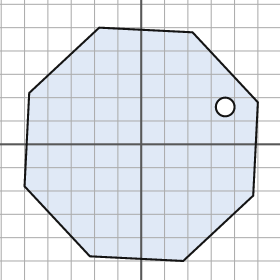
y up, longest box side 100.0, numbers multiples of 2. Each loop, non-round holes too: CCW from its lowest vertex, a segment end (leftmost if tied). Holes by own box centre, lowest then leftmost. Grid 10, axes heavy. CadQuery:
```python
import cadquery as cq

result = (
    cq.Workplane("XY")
    .moveTo(18.0, -50.0)
    .lineTo(48.0, -22.0)
    .lineTo(50.0, 18.0)
    .lineTo(22.0, 48.0)
    .lineTo(-18.0, 50.0)
    .lineTo(-48.0, 22.0)
    .lineTo(-50.0, -18.0)
    .lineTo(-22.0, -48.0)
    .close()
    .moveTo(36.0, 16.0)
    .circle(4.0)
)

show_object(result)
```